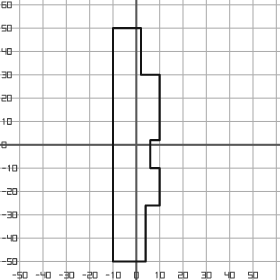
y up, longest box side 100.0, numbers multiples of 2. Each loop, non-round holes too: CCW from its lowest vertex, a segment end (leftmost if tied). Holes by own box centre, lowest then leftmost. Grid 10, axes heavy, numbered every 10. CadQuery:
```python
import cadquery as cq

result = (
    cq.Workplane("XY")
    .moveTo(-10.0, -50.0)
    .lineTo(4.0, -50.0)
    .lineTo(4.0, -26.0)
    .lineTo(10.0, -26.0)
    .lineTo(10.0, -10.0)
    .lineTo(6.0, -10.0)
    .lineTo(6.0, 2.0)
    .lineTo(10.0, 2.0)
    .lineTo(10.0, 30.0)
    .lineTo(2.0, 30.0)
    .lineTo(2.0, 50.0)
    .lineTo(-10.0, 50.0)
    .close()
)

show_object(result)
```